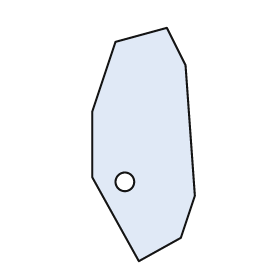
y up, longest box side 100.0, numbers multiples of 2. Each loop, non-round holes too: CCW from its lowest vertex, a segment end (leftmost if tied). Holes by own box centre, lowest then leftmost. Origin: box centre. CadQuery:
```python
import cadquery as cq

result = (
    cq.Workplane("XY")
    .moveTo(-2.0, -50.0)
    .lineTo(16.0, -40.0)
    .lineTo(22.0, -22.0)
    .lineTo(18.0, 34.0)
    .lineTo(10.0, 50.0)
    .lineTo(-12.0, 44.0)
    .lineTo(-22.0, 14.0)
    .lineTo(-22.0, -14.0)
    .close()
    .moveTo(-8.0, -16.0)
    .circle(4.0)
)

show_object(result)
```